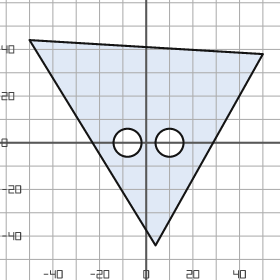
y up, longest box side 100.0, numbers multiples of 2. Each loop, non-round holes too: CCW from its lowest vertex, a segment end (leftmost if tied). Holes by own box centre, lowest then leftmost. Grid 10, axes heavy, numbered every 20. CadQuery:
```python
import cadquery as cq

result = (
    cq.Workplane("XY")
    .moveTo(4.0, -44.0)
    .lineTo(50.0, 38.0)
    .lineTo(-50.0, 44.0)
    .close()
    .moveTo(-8.0, 0.0)
    .circle(6.0)
    .moveTo(10.0, 0.0)
    .circle(6.0)
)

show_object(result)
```